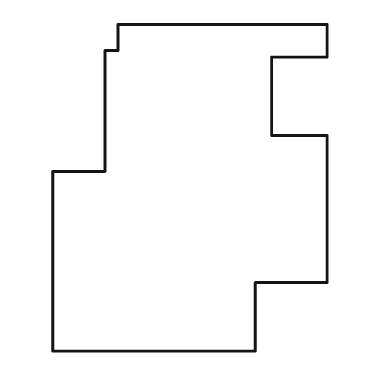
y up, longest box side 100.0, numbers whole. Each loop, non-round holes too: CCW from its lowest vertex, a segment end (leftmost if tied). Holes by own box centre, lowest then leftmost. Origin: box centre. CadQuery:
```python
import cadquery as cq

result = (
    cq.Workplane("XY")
    .moveTo(-42.0, -50.0)
    .lineTo(20.0, -50.0)
    .lineTo(20.0, -29.0)
    .lineTo(42.0, -29.0)
    .lineTo(42.0, 16.0)
    .lineTo(25.0, 16.0)
    .lineTo(25.0, 40.0)
    .lineTo(42.0, 40.0)
    .lineTo(42.0, 50.0)
    .lineTo(-22.0, 50.0)
    .lineTo(-22.0, 42.0)
    .lineTo(-26.0, 42.0)
    .lineTo(-26.0, 5.0)
    .lineTo(-42.0, 5.0)
    .close()
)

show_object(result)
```